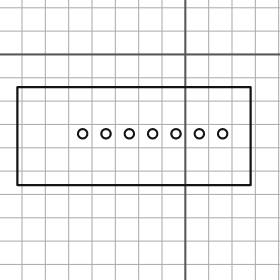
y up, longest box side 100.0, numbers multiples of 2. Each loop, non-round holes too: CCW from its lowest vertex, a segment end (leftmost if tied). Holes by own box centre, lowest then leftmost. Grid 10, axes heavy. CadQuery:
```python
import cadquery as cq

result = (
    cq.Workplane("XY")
    .moveTo(-72.0, -56.0)
    .lineTo(28.0, -56.0)
    .lineTo(28.0, -14.0)
    .lineTo(-72.0, -14.0)
    .close()
    .moveTo(-44.0, -34.0)
    .circle(2.0)
    .moveTo(-34.0, -34.0)
    .circle(2.0)
    .moveTo(-24.0, -34.0)
    .circle(2.0)
    .moveTo(-14.0, -34.0)
    .circle(2.0)
    .moveTo(-4.0, -34.0)
    .circle(2.0)
    .moveTo(6.0, -34.0)
    .circle(2.0)
    .moveTo(16.0, -34.0)
    .circle(2.0)
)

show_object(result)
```